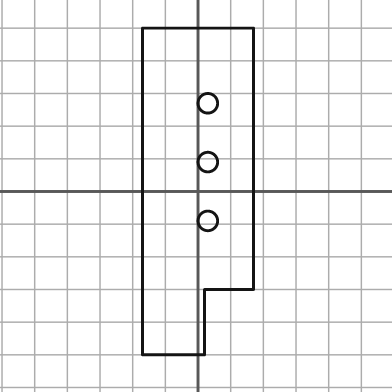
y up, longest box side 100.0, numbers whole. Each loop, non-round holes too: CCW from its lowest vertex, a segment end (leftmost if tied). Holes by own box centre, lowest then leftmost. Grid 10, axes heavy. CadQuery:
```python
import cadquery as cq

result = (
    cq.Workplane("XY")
    .moveTo(-17.0, -50.0)
    .lineTo(2.0, -50.0)
    .lineTo(2.0, -30.0)
    .lineTo(17.0, -30.0)
    .lineTo(17.0, 50.0)
    .lineTo(-17.0, 50.0)
    .close()
    .moveTo(3.0, -9.0)
    .circle(3.0)
    .moveTo(3.0, 9.0)
    .circle(3.0)
    .moveTo(3.0, 27.0)
    .circle(3.0)
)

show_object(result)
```